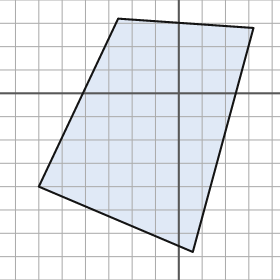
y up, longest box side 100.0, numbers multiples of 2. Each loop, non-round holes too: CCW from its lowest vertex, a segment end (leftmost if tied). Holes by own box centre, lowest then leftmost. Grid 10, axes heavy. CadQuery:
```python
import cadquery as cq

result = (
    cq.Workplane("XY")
    .moveTo(6.0, -68.0)
    .lineTo(32.0, 28.0)
    .lineTo(-26.0, 32.0)
    .lineTo(-60.0, -40.0)
    .close()
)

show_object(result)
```